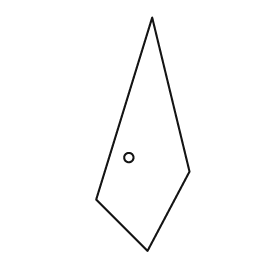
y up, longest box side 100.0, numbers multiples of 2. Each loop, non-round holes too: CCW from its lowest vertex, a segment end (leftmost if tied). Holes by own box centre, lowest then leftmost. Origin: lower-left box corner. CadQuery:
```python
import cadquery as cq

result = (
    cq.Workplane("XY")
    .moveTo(22.0, 0.0)
    .lineTo(40.0, 34.0)
    .lineTo(24.0, 100.0)
    .lineTo(0.0, 22.0)
    .close()
    .moveTo(14.0, 40.0)
    .circle(2.0)
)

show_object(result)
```